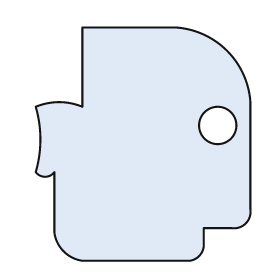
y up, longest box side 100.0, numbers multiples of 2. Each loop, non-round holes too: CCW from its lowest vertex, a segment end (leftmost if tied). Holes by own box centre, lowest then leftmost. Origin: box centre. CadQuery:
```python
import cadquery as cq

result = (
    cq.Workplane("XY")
    .moveTo(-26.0, -50.0)
    .lineTo(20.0, -50.0)
    .threePointArc((24.0, -48.0), (26.0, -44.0))
    .lineTo(26.0, -36.0)
    .lineTo(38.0, -36.0)
    .threePointArc((44.0, -34.0), (46.0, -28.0))
    .lineTo(46.0, 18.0)
    .threePointArc((36.0, 40.0), (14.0, 50.0))
    .lineTo(-26.0, 50.0)
    .lineTo(-26.0, 16.0)
    .threePointArc((-36.0, 18.0), (-46.0, 16.0))
    .threePointArc((-44.0, 2.0), (-46.0, -12.0))
    .threePointArc((-42.0, -14.0), (-38.0, -12.0))
    .lineTo(-38.0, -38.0)
    .threePointArc((-34.0, -46.0), (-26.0, -50.0))
    .close()
    .moveTo(32.0, 8.0)
    .circle(8.0)
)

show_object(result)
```